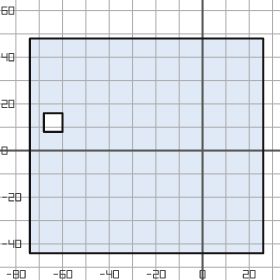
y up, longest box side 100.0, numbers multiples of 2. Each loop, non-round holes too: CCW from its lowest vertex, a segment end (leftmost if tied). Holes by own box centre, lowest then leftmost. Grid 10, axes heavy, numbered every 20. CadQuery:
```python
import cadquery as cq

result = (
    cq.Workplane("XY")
    .moveTo(-74.0, -44.0)
    .lineTo(26.0, -44.0)
    .lineTo(26.0, 48.0)
    .lineTo(-74.0, 48.0)
    .close()
    .moveTo(-68.0, 8.0)
    .lineTo(-60.0, 8.0)
    .lineTo(-60.0, 16.0)
    .lineTo(-68.0, 16.0)
    .close()
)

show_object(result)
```